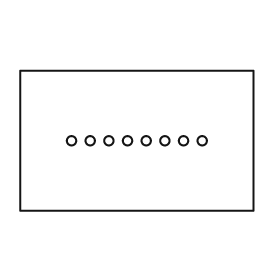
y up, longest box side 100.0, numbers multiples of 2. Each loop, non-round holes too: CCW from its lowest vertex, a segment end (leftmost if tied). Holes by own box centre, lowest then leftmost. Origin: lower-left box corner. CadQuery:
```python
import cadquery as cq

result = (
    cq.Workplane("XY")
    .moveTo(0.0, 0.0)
    .lineTo(100.0, 0.0)
    .lineTo(100.0, 60.0)
    .lineTo(0.0, 60.0)
    .close()
    .moveTo(22.0, 30.0)
    .circle(2.0)
    .moveTo(30.0, 30.0)
    .circle(2.0)
    .moveTo(38.0, 30.0)
    .circle(2.0)
    .moveTo(46.0, 30.0)
    .circle(2.0)
    .moveTo(54.0, 30.0)
    .circle(2.0)
    .moveTo(62.0, 30.0)
    .circle(2.0)
    .moveTo(70.0, 30.0)
    .circle(2.0)
    .moveTo(78.0, 30.0)
    .circle(2.0)
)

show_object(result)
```